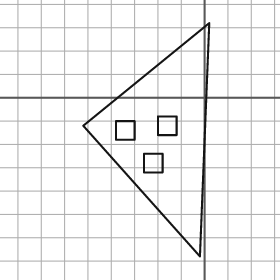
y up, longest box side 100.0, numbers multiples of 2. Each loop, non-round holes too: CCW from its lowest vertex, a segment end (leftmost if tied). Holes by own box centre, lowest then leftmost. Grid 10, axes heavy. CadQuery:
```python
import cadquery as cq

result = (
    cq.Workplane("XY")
    .moveTo(-2.0, -68.0)
    .lineTo(2.0, 32.0)
    .lineTo(-52.0, -12.0)
    .close()
    .moveTo(-26.0, -32.0)
    .lineTo(-18.0, -32.0)
    .lineTo(-18.0, -24.0)
    .lineTo(-26.0, -24.0)
    .close()
    .moveTo(-38.0, -18.0)
    .lineTo(-30.0, -18.0)
    .lineTo(-30.0, -10.0)
    .lineTo(-38.0, -10.0)
    .close()
    .moveTo(-20.0, -16.0)
    .lineTo(-12.0, -16.0)
    .lineTo(-12.0, -8.0)
    .lineTo(-20.0, -8.0)
    .close()
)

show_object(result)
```